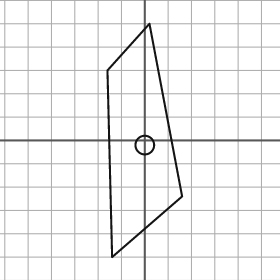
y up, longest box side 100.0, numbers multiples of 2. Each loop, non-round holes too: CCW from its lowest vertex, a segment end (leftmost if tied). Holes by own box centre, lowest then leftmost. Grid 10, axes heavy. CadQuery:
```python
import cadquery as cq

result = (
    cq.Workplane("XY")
    .moveTo(-14.0, -50.0)
    .lineTo(16.0, -24.0)
    .lineTo(2.0, 50.0)
    .lineTo(-16.0, 30.0)
    .close()
    .moveTo(0.0, -2.0)
    .circle(4.0)
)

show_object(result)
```